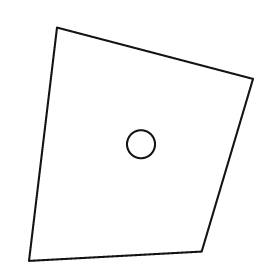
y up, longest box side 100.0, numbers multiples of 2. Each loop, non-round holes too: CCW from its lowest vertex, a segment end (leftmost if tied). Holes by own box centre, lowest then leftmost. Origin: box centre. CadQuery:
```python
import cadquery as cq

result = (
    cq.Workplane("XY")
    .moveTo(-48.0, -50.0)
    .lineTo(26.0, -46.0)
    .lineTo(48.0, 28.0)
    .lineTo(-36.0, 50.0)
    .close()
    .moveTo(0.0, 0.0)
    .circle(6.0)
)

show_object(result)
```